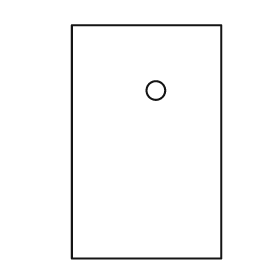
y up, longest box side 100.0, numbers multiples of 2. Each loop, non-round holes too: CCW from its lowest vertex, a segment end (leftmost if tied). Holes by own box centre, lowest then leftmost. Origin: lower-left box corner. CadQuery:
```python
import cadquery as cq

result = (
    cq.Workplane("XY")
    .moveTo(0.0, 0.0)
    .lineTo(64.0, 0.0)
    .lineTo(64.0, 100.0)
    .lineTo(0.0, 100.0)
    .close()
    .moveTo(36.0, 72.0)
    .circle(4.0)
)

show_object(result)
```